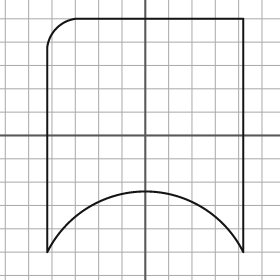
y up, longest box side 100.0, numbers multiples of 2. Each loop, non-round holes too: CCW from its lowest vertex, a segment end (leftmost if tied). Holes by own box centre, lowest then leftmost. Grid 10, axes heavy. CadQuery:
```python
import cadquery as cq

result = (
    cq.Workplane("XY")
    .moveTo(-42.0, -50.0)
    .threePointArc((0.0, -24.0), (42.0, -50.0))
    .lineTo(42.0, 50.0)
    .lineTo(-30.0, 50.0)
    .threePointArc((-38.0, 46.0), (-42.0, 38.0))
    .close()
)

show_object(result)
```